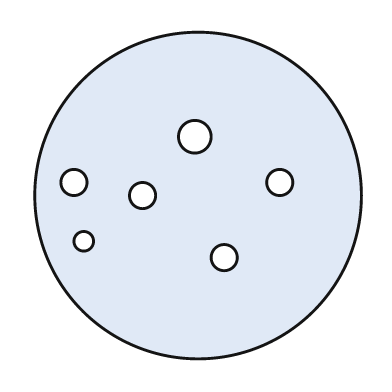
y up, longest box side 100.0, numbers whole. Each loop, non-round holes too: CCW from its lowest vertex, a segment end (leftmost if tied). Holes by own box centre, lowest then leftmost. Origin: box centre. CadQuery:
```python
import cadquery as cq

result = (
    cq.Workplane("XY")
    .moveTo(0.0, 0.0)
    .circle(50.0)
    .moveTo(8.0, -19.0)
    .circle(4.0)
    .moveTo(-35.0, -14.0)
    .circle(3.0)
    .moveTo(-17.0, 0.0)
    .circle(4.0)
    .moveTo(-38.0, 4.0)
    .circle(4.0)
    .moveTo(25.0, 4.0)
    .circle(4.0)
    .moveTo(-1.0, 18.0)
    .circle(5.0)
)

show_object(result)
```